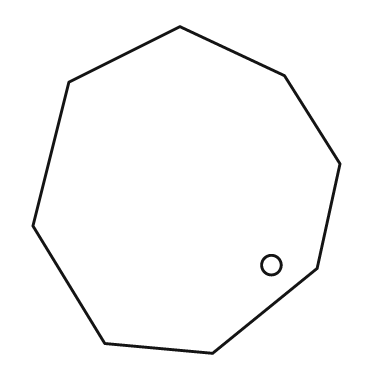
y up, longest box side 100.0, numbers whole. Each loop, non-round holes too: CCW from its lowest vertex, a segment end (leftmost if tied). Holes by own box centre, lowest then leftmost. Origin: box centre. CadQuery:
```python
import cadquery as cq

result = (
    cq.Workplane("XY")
    .moveTo(8.0, -50.0)
    .lineTo(40.0, -24.0)
    .lineTo(47.0, 8.0)
    .lineTo(30.0, 35.0)
    .lineTo(-2.0, 50.0)
    .lineTo(-36.0, 33.0)
    .lineTo(-47.0, -11.0)
    .lineTo(-25.0, -47.0)
    .close()
    .moveTo(26.0, -23.0)
    .circle(3.0)
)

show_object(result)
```